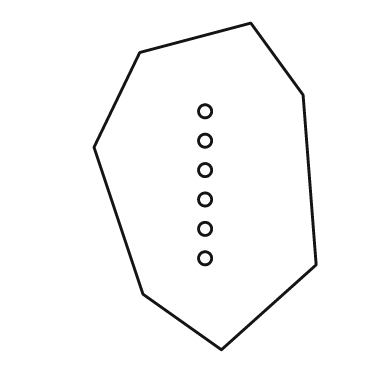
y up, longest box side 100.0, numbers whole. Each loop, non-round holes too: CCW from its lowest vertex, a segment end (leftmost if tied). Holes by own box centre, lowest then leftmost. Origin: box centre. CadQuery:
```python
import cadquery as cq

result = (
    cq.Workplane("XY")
    .moveTo(5.0, -50.0)
    .lineTo(34.0, -24.0)
    .lineTo(30.0, 28.0)
    .lineTo(14.0, 50.0)
    .lineTo(-20.0, 41.0)
    .lineTo(-34.0, 12.0)
    .lineTo(-19.0, -33.0)
    .close()
    .moveTo(0.0, -22.0)
    .circle(2.0)
    .moveTo(0.0, -13.0)
    .circle(2.0)
    .moveTo(0.0, -4.0)
    .circle(2.0)
    .moveTo(0.0, 5.0)
    .circle(2.0)
    .moveTo(0.0, 14.0)
    .circle(2.0)
    .moveTo(0.0, 23.0)
    .circle(2.0)
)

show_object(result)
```